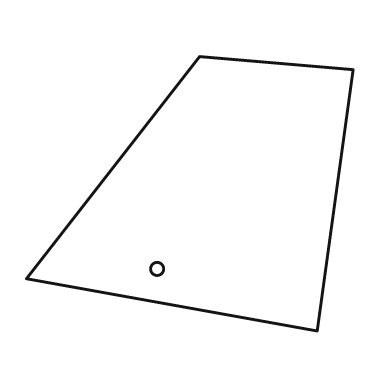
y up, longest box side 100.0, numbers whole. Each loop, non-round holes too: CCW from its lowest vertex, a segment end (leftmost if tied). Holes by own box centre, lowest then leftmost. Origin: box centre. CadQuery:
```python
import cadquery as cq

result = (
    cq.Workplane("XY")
    .moveTo(39.0, -42.0)
    .lineTo(50.0, 38.0)
    .lineTo(3.0, 42.0)
    .lineTo(-50.0, -26.0)
    .close()
    .moveTo(-10.0, -23.0)
    .circle(2.0)
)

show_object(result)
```